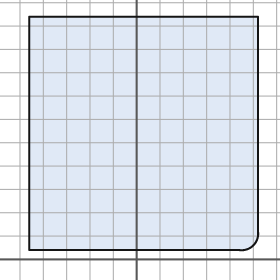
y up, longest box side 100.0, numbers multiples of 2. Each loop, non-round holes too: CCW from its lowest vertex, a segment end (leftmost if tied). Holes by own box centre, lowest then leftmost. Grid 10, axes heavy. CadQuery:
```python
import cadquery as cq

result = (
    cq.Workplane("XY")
    .moveTo(-46.0, 4.0)
    .lineTo(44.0, 4.0)
    .threePointArc((50.0, 6.0), (52.0, 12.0))
    .lineTo(52.0, 104.0)
    .lineTo(-46.0, 104.0)
    .close()
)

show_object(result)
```